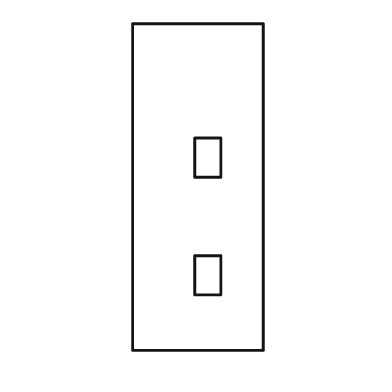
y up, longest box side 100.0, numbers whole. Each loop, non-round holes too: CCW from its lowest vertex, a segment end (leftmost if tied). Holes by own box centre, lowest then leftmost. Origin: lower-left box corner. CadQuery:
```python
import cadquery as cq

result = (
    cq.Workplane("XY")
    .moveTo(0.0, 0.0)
    .lineTo(40.0, 0.0)
    .lineTo(40.0, 100.0)
    .lineTo(0.0, 100.0)
    .close()
    .moveTo(19.0, 17.0)
    .lineTo(27.0, 17.0)
    .lineTo(27.0, 29.0)
    .lineTo(19.0, 29.0)
    .close()
    .moveTo(19.0, 53.0)
    .lineTo(27.0, 53.0)
    .lineTo(27.0, 65.0)
    .lineTo(19.0, 65.0)
    .close()
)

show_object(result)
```